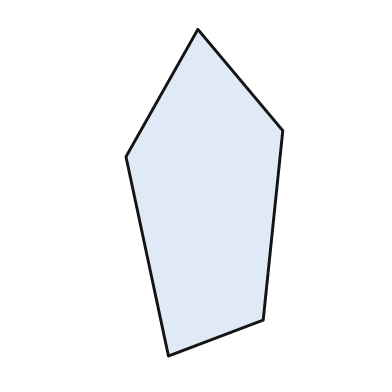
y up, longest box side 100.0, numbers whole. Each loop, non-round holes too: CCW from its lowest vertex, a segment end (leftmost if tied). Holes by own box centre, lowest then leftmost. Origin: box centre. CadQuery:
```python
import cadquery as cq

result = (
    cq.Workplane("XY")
    .moveTo(-11.0, -50.0)
    .lineTo(18.0, -39.0)
    .lineTo(24.0, 19.0)
    .lineTo(-2.0, 50.0)
    .lineTo(-24.0, 11.0)
    .close()
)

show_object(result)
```